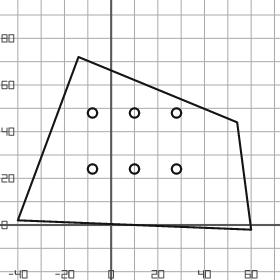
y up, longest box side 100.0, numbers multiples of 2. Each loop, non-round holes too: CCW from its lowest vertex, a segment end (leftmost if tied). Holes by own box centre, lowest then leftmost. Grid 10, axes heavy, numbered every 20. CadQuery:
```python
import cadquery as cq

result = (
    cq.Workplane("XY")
    .moveTo(60.0, -2.0)
    .lineTo(54.0, 44.0)
    .lineTo(-14.0, 72.0)
    .lineTo(-40.0, 2.0)
    .close()
    .moveTo(-8.0, 24.0)
    .circle(2.0)
    .moveTo(10.0, 24.0)
    .circle(2.0)
    .moveTo(28.0, 24.0)
    .circle(2.0)
    .moveTo(-8.0, 48.0)
    .circle(2.0)
    .moveTo(10.0, 48.0)
    .circle(2.0)
    .moveTo(28.0, 48.0)
    .circle(2.0)
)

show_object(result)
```